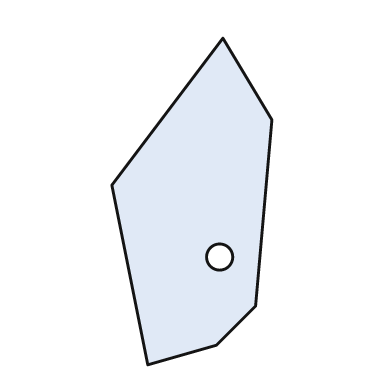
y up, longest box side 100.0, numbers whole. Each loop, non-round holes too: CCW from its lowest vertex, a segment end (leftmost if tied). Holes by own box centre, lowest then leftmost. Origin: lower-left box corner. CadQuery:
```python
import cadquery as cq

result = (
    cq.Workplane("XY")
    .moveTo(11.0, 0.0)
    .lineTo(32.0, 6.0)
    .lineTo(44.0, 18.0)
    .lineTo(49.0, 75.0)
    .lineTo(34.0, 100.0)
    .lineTo(0.0, 55.0)
    .close()
    .moveTo(33.0, 33.0)
    .circle(4.0)
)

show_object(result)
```